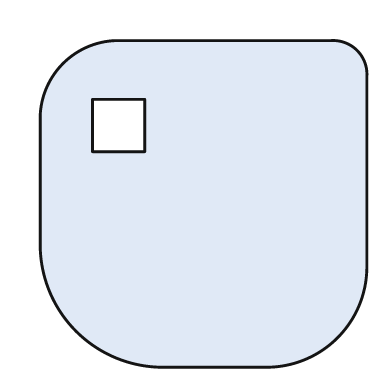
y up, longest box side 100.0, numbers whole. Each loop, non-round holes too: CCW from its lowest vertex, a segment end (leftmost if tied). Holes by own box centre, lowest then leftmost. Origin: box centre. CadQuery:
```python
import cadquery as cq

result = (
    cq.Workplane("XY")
    .moveTo(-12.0, -50.0)
    .lineTo(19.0, -50.0)
    .threePointArc((41.0, -41.0), (50.0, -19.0))
    .lineTo(50.0, 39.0)
    .threePointArc((47.0, 47.0), (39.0, 50.0))
    .lineTo(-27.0, 50.0)
    .threePointArc((-43.0, 43.0), (-50.0, 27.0))
    .lineTo(-50.0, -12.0)
    .threePointArc((-39.0, -39.0), (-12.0, -50.0))
    .close()
    .moveTo(-34.0, 16.0)
    .lineTo(-18.0, 16.0)
    .lineTo(-18.0, 32.0)
    .lineTo(-34.0, 32.0)
    .close()
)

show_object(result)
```